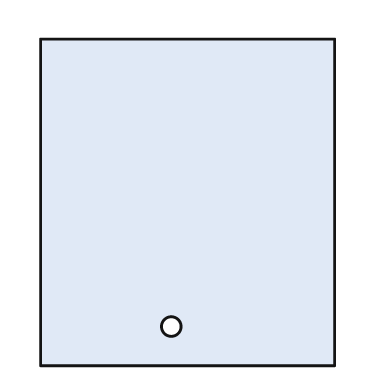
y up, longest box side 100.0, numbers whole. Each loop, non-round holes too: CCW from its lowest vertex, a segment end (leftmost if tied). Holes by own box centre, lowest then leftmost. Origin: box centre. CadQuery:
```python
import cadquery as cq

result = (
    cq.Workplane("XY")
    .moveTo(-45.0, -50.0)
    .lineTo(45.0, -50.0)
    .lineTo(45.0, 50.0)
    .lineTo(-45.0, 50.0)
    .close()
    .moveTo(-5.0, -38.0)
    .circle(3.0)
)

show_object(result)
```